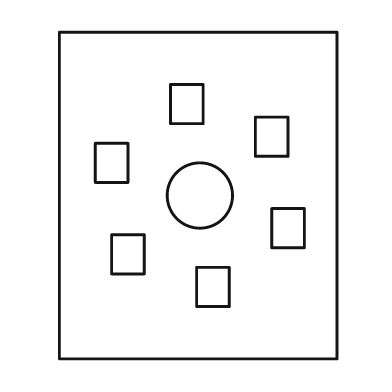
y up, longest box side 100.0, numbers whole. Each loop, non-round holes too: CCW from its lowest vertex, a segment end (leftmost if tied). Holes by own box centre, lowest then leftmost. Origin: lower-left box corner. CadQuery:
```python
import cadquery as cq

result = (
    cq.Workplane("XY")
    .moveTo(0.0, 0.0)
    .lineTo(85.0, 0.0)
    .lineTo(85.0, 100.0)
    .lineTo(0.0, 100.0)
    .close()
    .moveTo(42.0, 16.0)
    .lineTo(52.0, 16.0)
    .lineTo(52.0, 28.0)
    .lineTo(42.0, 28.0)
    .close()
    .moveTo(16.0, 26.0)
    .lineTo(26.0, 26.0)
    .lineTo(26.0, 38.0)
    .lineTo(16.0, 38.0)
    .close()
    .moveTo(65.0, 34.0)
    .lineTo(75.0, 34.0)
    .lineTo(75.0, 46.0)
    .lineTo(65.0, 46.0)
    .close()
    .moveTo(43.0, 50.0)
    .circle(10.0)
    .moveTo(11.0, 54.0)
    .lineTo(21.0, 54.0)
    .lineTo(21.0, 66.0)
    .lineTo(11.0, 66.0)
    .close()
    .moveTo(60.0, 62.0)
    .lineTo(70.0, 62.0)
    .lineTo(70.0, 74.0)
    .lineTo(60.0, 74.0)
    .close()
    .moveTo(34.0, 72.0)
    .lineTo(44.0, 72.0)
    .lineTo(44.0, 84.0)
    .lineTo(34.0, 84.0)
    .close()
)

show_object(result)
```